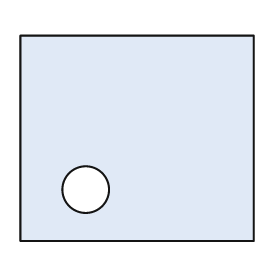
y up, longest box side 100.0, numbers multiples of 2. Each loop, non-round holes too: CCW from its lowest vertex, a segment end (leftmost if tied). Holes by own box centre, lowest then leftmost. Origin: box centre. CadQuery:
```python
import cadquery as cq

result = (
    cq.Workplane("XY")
    .moveTo(-50.0, -44.0)
    .lineTo(50.0, -44.0)
    .lineTo(50.0, 44.0)
    .lineTo(-50.0, 44.0)
    .close()
    .moveTo(-22.0, -22.0)
    .circle(10.0)
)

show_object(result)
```